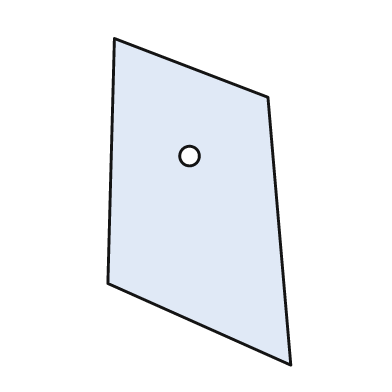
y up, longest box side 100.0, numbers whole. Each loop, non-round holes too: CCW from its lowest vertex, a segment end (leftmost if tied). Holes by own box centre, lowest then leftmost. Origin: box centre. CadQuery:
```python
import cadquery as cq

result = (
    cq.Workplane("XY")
    .moveTo(28.0, -50.0)
    .lineTo(21.0, 32.0)
    .lineTo(-26.0, 50.0)
    .lineTo(-28.0, -25.0)
    .close()
    .moveTo(-3.0, 14.0)
    .circle(3.0)
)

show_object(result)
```